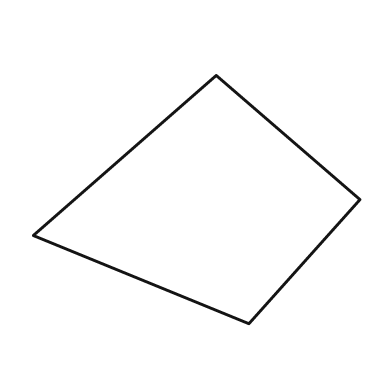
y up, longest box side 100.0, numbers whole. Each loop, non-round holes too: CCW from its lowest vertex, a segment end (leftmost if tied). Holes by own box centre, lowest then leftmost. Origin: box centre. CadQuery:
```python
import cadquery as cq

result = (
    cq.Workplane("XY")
    .moveTo(16.0, -38.0)
    .lineTo(50.0, 0.0)
    .lineTo(6.0, 38.0)
    .lineTo(-50.0, -11.0)
    .close()
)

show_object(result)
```